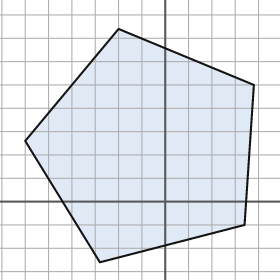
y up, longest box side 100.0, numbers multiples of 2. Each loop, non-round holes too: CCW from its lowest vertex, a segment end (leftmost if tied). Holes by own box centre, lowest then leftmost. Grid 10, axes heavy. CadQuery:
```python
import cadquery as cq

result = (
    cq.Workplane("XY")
    .moveTo(-28.0, -26.0)
    .lineTo(34.0, -10.0)
    .lineTo(38.0, 50.0)
    .lineTo(-20.0, 74.0)
    .lineTo(-60.0, 26.0)
    .close()
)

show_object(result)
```